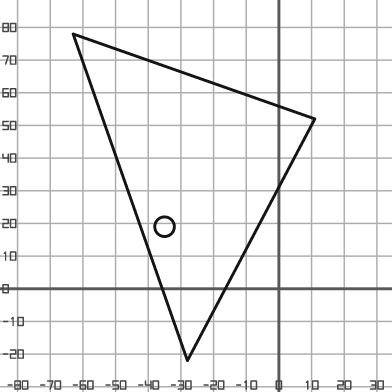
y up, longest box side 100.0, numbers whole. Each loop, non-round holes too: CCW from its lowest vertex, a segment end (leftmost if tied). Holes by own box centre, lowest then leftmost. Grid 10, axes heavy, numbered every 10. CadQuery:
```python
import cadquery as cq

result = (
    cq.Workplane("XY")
    .moveTo(-28.0, -22.0)
    .lineTo(11.0, 52.0)
    .lineTo(-63.0, 78.0)
    .close()
    .moveTo(-35.0, 19.0)
    .circle(3.0)
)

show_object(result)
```